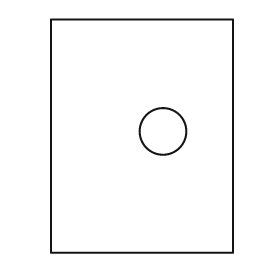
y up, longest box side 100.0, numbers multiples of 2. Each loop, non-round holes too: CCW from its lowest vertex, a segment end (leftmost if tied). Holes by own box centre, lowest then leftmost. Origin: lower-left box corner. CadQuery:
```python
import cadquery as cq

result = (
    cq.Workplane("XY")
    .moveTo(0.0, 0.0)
    .lineTo(78.0, 0.0)
    .lineTo(78.0, 100.0)
    .lineTo(0.0, 100.0)
    .close()
    .moveTo(48.0, 52.0)
    .circle(10.0)
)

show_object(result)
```